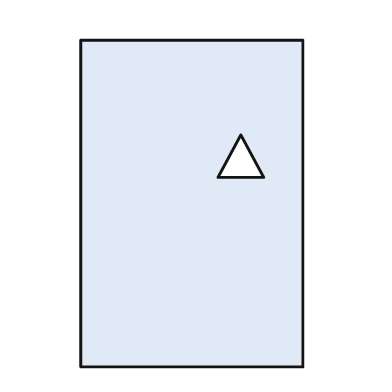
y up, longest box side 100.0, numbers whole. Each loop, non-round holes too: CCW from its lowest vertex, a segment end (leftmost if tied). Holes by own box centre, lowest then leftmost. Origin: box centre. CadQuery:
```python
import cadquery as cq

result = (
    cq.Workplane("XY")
    .moveTo(-34.0, -50.0)
    .lineTo(34.0, -50.0)
    .lineTo(34.0, 50.0)
    .lineTo(-34.0, 50.0)
    .close()
    .moveTo(8.0, 8.0)
    .lineTo(22.0, 8.0)
    .lineTo(15.0, 21.0)
    .close()
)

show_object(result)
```